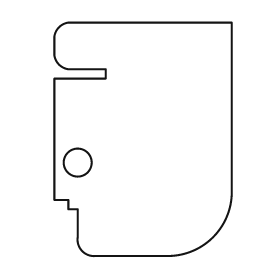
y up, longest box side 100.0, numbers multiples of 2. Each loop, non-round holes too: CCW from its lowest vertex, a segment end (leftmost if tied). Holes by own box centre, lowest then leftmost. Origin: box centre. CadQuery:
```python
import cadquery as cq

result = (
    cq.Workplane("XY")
    .moveTo(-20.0, -50.0)
    .lineTo(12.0, -50.0)
    .threePointArc((30.0, -42.0), (38.0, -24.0))
    .lineTo(38.0, 50.0)
    .lineTo(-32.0, 50.0)
    .threePointArc((-36.0, 48.0), (-38.0, 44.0))
    .lineTo(-38.0, 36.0)
    .threePointArc((-36.0, 32.0), (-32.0, 30.0))
    .lineTo(-16.0, 30.0)
    .lineTo(-16.0, 26.0)
    .lineTo(-38.0, 26.0)
    .lineTo(-38.0, -26.0)
    .lineTo(-32.0, -26.0)
    .lineTo(-32.0, -30.0)
    .lineTo(-28.0, -30.0)
    .lineTo(-28.0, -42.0)
    .threePointArc((-26.0, -48.0), (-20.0, -50.0))
    .close()
    .moveTo(-28.0, -10.0)
    .circle(6.0)
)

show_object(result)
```